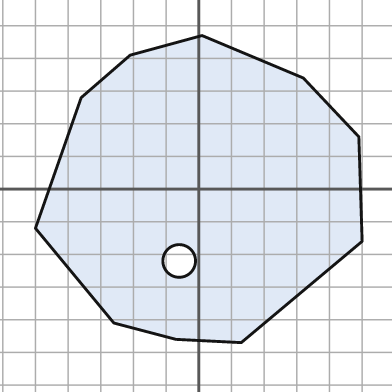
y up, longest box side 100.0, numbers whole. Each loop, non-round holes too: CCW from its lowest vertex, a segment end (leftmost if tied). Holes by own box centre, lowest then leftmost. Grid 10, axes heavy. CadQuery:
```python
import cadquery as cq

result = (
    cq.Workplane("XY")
    .moveTo(13.0, -47.0)
    .lineTo(50.0, -16.0)
    .lineTo(49.0, 16.0)
    .lineTo(32.0, 34.0)
    .lineTo(1.0, 47.0)
    .lineTo(-21.0, 41.0)
    .lineTo(-36.0, 28.0)
    .lineTo(-50.0, -12.0)
    .lineTo(-26.0, -41.0)
    .lineTo(-7.0, -46.0)
    .close()
    .moveTo(-6.0, -22.0)
    .circle(5.0)
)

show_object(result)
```